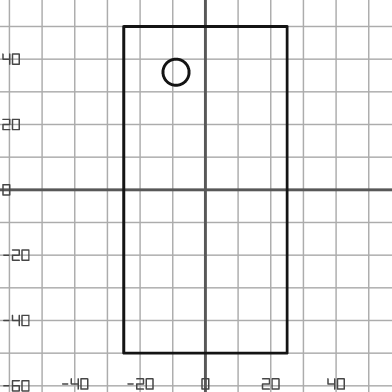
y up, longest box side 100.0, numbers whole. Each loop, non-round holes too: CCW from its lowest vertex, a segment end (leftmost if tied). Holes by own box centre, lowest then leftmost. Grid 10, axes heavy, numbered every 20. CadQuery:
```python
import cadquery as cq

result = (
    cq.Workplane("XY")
    .moveTo(-25.0, -50.0)
    .lineTo(25.0, -50.0)
    .lineTo(25.0, 50.0)
    .lineTo(-25.0, 50.0)
    .close()
    .moveTo(-9.0, 36.0)
    .circle(4.0)
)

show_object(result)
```